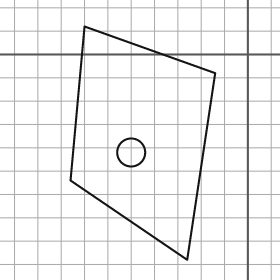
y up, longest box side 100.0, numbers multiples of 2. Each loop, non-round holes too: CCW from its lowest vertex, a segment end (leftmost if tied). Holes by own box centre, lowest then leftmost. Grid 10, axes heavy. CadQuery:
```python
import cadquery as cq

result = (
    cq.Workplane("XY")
    .moveTo(-26.0, -88.0)
    .lineTo(-14.0, -8.0)
    .lineTo(-70.0, 12.0)
    .lineTo(-76.0, -54.0)
    .close()
    .moveTo(-50.0, -42.0)
    .circle(6.0)
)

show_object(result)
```